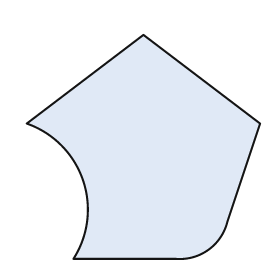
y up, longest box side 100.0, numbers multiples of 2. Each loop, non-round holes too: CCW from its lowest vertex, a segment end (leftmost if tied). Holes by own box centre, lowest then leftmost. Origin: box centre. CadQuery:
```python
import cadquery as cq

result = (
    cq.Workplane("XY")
    .moveTo(-30.0, -48.0)
    .lineTo(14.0, -48.0)
    .threePointArc((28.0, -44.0), (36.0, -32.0))
    .lineTo(50.0, 10.0)
    .lineTo(0.0, 48.0)
    .lineTo(-50.0, 10.0)
    .threePointArc((-26.0, -14.0), (-30.0, -48.0))
    .close()
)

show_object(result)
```